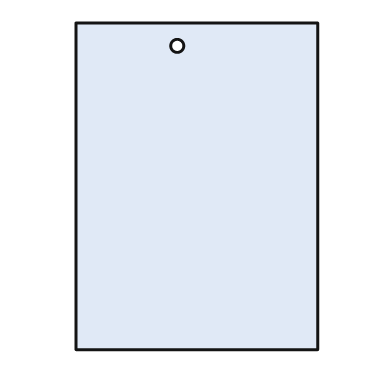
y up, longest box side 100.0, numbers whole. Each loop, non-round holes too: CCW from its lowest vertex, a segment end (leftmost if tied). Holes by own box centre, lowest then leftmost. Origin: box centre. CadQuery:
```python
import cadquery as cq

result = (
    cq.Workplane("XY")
    .moveTo(-37.0, -50.0)
    .lineTo(37.0, -50.0)
    .lineTo(37.0, 50.0)
    .lineTo(-37.0, 50.0)
    .close()
    .moveTo(-6.0, 43.0)
    .circle(2.0)
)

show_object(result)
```